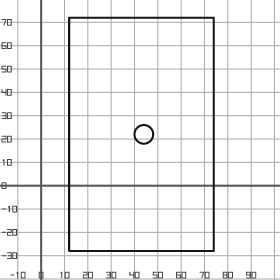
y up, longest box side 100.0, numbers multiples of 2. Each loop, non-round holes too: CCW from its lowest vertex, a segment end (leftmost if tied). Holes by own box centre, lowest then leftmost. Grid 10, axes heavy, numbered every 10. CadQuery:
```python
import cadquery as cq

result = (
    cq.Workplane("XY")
    .moveTo(12.0, -28.0)
    .lineTo(74.0, -28.0)
    .lineTo(74.0, 72.0)
    .lineTo(12.0, 72.0)
    .close()
    .moveTo(44.0, 22.0)
    .circle(4.0)
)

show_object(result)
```